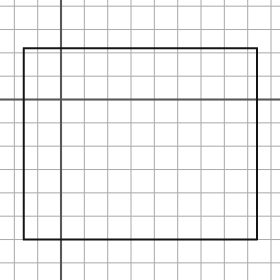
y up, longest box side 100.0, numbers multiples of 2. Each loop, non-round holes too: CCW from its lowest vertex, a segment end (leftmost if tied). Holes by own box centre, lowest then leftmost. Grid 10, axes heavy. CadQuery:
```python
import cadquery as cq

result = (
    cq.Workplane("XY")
    .moveTo(-16.0, -60.0)
    .lineTo(84.0, -60.0)
    .lineTo(84.0, 22.0)
    .lineTo(-16.0, 22.0)
    .close()
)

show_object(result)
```